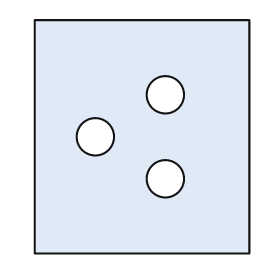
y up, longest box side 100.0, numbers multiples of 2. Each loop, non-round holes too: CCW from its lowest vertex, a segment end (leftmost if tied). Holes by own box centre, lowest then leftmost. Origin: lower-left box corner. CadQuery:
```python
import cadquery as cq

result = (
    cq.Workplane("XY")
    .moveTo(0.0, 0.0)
    .lineTo(92.0, 0.0)
    .lineTo(92.0, 100.0)
    .lineTo(0.0, 100.0)
    .close()
    .moveTo(56.0, 32.0)
    .circle(8.0)
    .moveTo(26.0, 50.0)
    .circle(8.0)
    .moveTo(56.0, 68.0)
    .circle(8.0)
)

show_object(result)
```